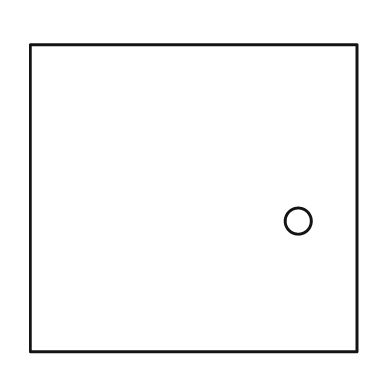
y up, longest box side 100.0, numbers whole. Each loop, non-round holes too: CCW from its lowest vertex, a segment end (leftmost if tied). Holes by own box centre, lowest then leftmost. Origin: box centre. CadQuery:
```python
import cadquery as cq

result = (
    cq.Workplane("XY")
    .moveTo(-50.0, -47.0)
    .lineTo(50.0, -47.0)
    .lineTo(50.0, 47.0)
    .lineTo(-50.0, 47.0)
    .close()
    .moveTo(32.0, -7.0)
    .circle(4.0)
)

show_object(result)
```